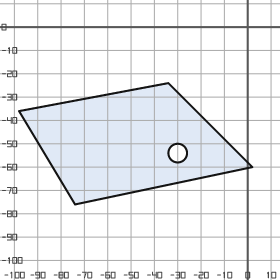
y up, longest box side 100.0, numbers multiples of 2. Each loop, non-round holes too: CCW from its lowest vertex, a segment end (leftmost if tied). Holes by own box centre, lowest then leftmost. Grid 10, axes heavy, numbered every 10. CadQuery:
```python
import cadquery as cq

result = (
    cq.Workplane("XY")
    .moveTo(-74.0, -76.0)
    .lineTo(2.0, -60.0)
    .lineTo(-34.0, -24.0)
    .lineTo(-98.0, -36.0)
    .close()
    .moveTo(-30.0, -54.0)
    .circle(4.0)
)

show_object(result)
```